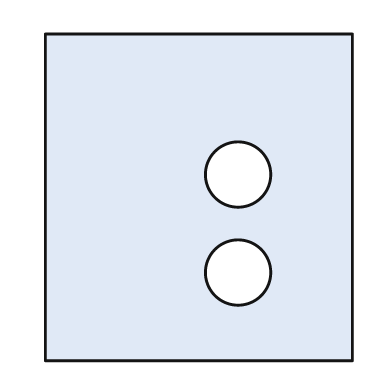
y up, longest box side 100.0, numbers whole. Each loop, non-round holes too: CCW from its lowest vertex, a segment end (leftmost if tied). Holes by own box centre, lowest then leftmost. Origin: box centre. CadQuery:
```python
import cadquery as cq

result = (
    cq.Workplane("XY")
    .moveTo(-47.0, -50.0)
    .lineTo(47.0, -50.0)
    .lineTo(47.0, 50.0)
    .lineTo(-47.0, 50.0)
    .close()
    .moveTo(12.0, -23.0)
    .circle(10.0)
    .moveTo(12.0, 7.0)
    .circle(10.0)
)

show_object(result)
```